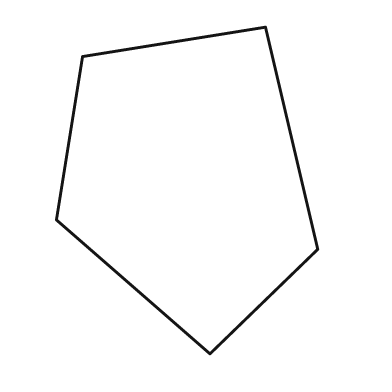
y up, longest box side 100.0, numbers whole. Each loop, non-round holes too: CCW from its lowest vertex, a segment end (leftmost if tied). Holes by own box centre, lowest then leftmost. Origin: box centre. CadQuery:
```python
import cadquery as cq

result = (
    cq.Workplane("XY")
    .moveTo(7.0, -50.0)
    .lineTo(40.0, -18.0)
    .lineTo(24.0, 50.0)
    .lineTo(-32.0, 41.0)
    .lineTo(-40.0, -9.0)
    .close()
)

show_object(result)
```